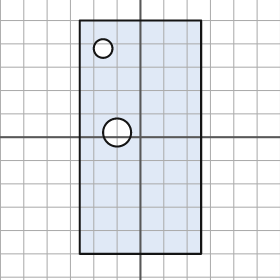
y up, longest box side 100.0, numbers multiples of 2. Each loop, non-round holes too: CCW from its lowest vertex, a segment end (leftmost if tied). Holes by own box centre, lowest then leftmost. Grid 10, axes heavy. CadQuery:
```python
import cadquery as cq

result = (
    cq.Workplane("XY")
    .moveTo(-26.0, -50.0)
    .lineTo(26.0, -50.0)
    .lineTo(26.0, 50.0)
    .lineTo(-26.0, 50.0)
    .close()
    .moveTo(-10.0, 2.0)
    .circle(6.0)
    .moveTo(-16.0, 38.0)
    .circle(4.0)
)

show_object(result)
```